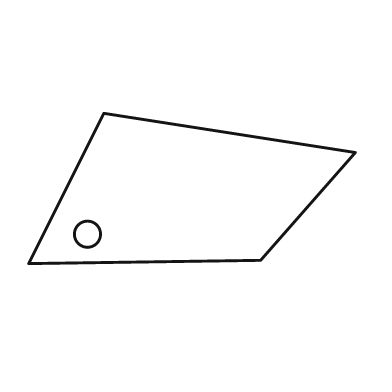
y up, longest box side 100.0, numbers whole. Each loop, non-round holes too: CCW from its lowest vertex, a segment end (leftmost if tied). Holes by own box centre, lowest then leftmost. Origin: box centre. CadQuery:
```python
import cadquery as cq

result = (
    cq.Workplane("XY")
    .moveTo(-50.0, -23.0)
    .lineTo(21.0, -22.0)
    .lineTo(50.0, 11.0)
    .lineTo(-27.0, 23.0)
    .close()
    .moveTo(-32.0, -14.0)
    .circle(4.0)
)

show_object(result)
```